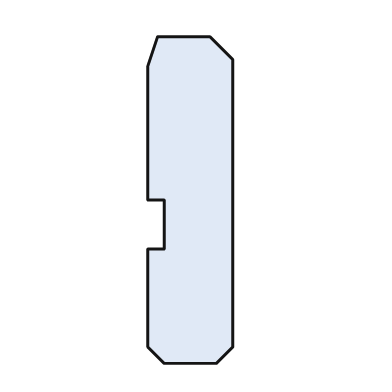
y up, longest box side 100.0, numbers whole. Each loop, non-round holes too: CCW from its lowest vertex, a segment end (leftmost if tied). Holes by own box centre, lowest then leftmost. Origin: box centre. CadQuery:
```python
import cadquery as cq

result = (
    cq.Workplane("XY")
    .moveTo(-8.0, -50.0)
    .lineTo(8.0, -50.0)
    .lineTo(13.0, -45.0)
    .lineTo(13.0, 43.0)
    .lineTo(6.0, 50.0)
    .lineTo(-10.0, 50.0)
    .lineTo(-13.0, 41.0)
    .lineTo(-13.0, 0.0)
    .lineTo(-8.0, 0.0)
    .lineTo(-8.0, -15.0)
    .lineTo(-13.0, -15.0)
    .lineTo(-13.0, -45.0)
    .close()
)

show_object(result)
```